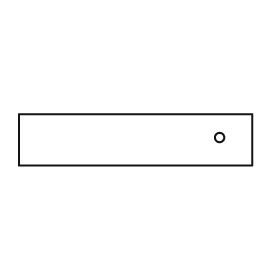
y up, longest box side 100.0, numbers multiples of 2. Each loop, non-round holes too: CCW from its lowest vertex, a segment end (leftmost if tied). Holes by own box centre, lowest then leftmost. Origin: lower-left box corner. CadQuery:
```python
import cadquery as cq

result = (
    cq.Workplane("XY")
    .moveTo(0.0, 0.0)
    .lineTo(100.0, 0.0)
    .lineTo(100.0, 22.0)
    .lineTo(0.0, 22.0)
    .close()
    .moveTo(86.0, 12.0)
    .circle(2.0)
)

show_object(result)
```